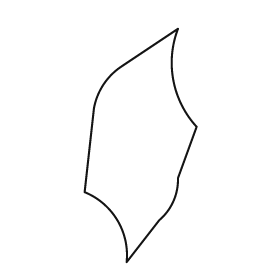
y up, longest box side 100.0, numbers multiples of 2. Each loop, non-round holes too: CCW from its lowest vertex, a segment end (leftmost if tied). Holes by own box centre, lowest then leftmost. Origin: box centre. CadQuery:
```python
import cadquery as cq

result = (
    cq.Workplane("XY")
    .moveTo(-6.0, -50.0)
    .lineTo(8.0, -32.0)
    .threePointArc((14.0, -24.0), (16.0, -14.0))
    .lineTo(24.0, 8.0)
    .threePointArc((14.0, 28.0), (16.0, 50.0))
    .lineTo(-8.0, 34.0)
    .threePointArc((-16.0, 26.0), (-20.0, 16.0))
    .lineTo(-24.0, -20.0)
    .threePointArc((-10.0, -32.0), (-6.0, -50.0))
    .close()
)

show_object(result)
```